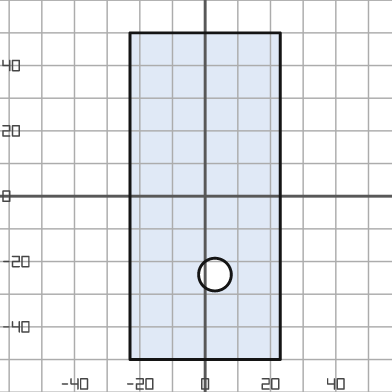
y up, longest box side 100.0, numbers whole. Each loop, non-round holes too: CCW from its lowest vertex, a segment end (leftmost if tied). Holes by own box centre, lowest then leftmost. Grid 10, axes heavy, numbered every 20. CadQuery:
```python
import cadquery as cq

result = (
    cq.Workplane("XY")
    .moveTo(-23.0, -50.0)
    .lineTo(23.0, -50.0)
    .lineTo(23.0, 50.0)
    .lineTo(-23.0, 50.0)
    .close()
    .moveTo(3.0, -24.0)
    .circle(5.0)
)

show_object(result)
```